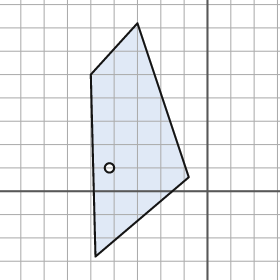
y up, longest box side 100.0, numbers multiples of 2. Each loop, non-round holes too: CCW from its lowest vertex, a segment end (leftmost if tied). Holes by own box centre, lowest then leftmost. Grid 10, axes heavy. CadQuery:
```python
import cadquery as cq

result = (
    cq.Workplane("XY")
    .moveTo(-48.0, -28.0)
    .lineTo(-8.0, 6.0)
    .lineTo(-30.0, 72.0)
    .lineTo(-50.0, 50.0)
    .close()
    .moveTo(-42.0, 10.0)
    .circle(2.0)
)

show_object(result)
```